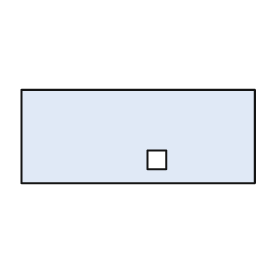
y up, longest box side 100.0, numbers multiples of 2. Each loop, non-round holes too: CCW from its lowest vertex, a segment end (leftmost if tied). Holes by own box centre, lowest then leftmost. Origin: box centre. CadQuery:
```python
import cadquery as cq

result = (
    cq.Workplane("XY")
    .moveTo(-50.0, -20.0)
    .lineTo(50.0, -20.0)
    .lineTo(50.0, 20.0)
    .lineTo(-50.0, 20.0)
    .close()
    .moveTo(4.0, -14.0)
    .lineTo(12.0, -14.0)
    .lineTo(12.0, -6.0)
    .lineTo(4.0, -6.0)
    .close()
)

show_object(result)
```